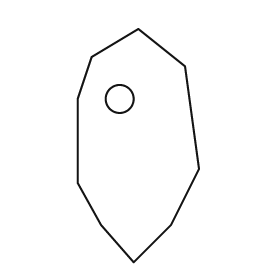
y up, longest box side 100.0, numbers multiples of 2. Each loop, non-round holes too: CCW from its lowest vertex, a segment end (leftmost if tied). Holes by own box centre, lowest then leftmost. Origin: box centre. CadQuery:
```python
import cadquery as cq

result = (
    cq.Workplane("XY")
    .moveTo(-2.0, -50.0)
    .lineTo(14.0, -34.0)
    .lineTo(26.0, -10.0)
    .lineTo(20.0, 34.0)
    .lineTo(0.0, 50.0)
    .lineTo(-20.0, 38.0)
    .lineTo(-26.0, 20.0)
    .lineTo(-26.0, -16.0)
    .lineTo(-16.0, -34.0)
    .close()
    .moveTo(-8.0, 20.0)
    .circle(6.0)
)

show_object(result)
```